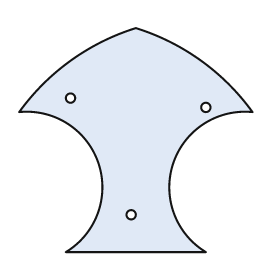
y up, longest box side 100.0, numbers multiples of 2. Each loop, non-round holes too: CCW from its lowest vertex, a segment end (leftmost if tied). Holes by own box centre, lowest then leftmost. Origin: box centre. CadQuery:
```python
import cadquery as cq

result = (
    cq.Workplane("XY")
    .moveTo(-30.0, -48.0)
    .lineTo(30.0, -48.0)
    .threePointArc((16.0, -10.0), (50.0, 12.0))
    .threePointArc((28.0, 34.0), (0.0, 48.0))
    .threePointArc((-28.0, 34.0), (-50.0, 12.0))
    .threePointArc((-16.0, -10.0), (-30.0, -48.0))
    .close()
    .moveTo(-2.0, -32.0)
    .circle(2.0)
    .moveTo(30.0, 14.0)
    .circle(2.0)
    .moveTo(-28.0, 18.0)
    .circle(2.0)
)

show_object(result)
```